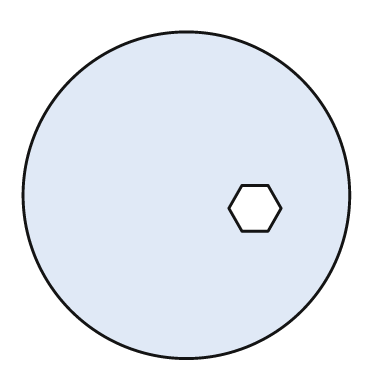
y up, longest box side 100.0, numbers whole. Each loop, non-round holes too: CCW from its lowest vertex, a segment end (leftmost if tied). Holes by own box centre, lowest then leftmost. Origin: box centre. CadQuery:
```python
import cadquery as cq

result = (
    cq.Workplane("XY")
    .moveTo(0.0, 0.0)
    .circle(50.0)
    .moveTo(17.0, -11.0)
    .lineTo(25.0, -11.0)
    .lineTo(29.0, -4.0)
    .lineTo(25.0, 3.0)
    .lineTo(17.0, 3.0)
    .lineTo(13.0, -4.0)
    .close()
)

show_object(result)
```